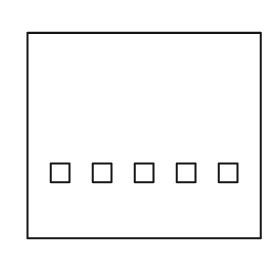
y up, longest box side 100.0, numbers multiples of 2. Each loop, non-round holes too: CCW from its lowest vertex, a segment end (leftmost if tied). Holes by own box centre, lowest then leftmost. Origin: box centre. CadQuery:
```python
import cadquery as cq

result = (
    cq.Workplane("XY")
    .moveTo(-50.0, -44.0)
    .lineTo(50.0, -44.0)
    .lineTo(50.0, 44.0)
    .lineTo(-50.0, 44.0)
    .close()
    .moveTo(-40.0, -20.0)
    .lineTo(-32.0, -20.0)
    .lineTo(-32.0, -12.0)
    .lineTo(-40.0, -12.0)
    .close()
    .moveTo(-22.0, -20.0)
    .lineTo(-14.0, -20.0)
    .lineTo(-14.0, -12.0)
    .lineTo(-22.0, -12.0)
    .close()
    .moveTo(-4.0, -20.0)
    .lineTo(4.0, -20.0)
    .lineTo(4.0, -12.0)
    .lineTo(-4.0, -12.0)
    .close()
    .moveTo(14.0, -20.0)
    .lineTo(22.0, -20.0)
    .lineTo(22.0, -12.0)
    .lineTo(14.0, -12.0)
    .close()
    .moveTo(32.0, -20.0)
    .lineTo(40.0, -20.0)
    .lineTo(40.0, -12.0)
    .lineTo(32.0, -12.0)
    .close()
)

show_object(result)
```